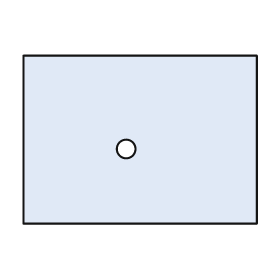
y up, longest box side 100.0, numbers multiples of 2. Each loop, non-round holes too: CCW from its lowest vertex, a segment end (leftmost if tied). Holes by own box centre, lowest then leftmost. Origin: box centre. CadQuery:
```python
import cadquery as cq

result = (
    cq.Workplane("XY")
    .moveTo(-50.0, -36.0)
    .lineTo(50.0, -36.0)
    .lineTo(50.0, 36.0)
    .lineTo(-50.0, 36.0)
    .close()
    .moveTo(-6.0, -4.0)
    .circle(4.0)
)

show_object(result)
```